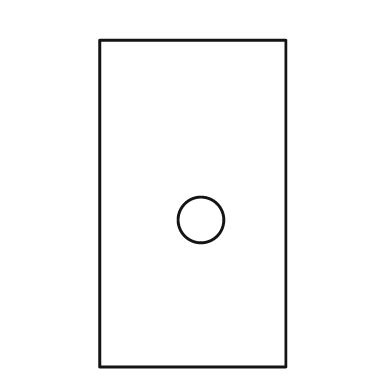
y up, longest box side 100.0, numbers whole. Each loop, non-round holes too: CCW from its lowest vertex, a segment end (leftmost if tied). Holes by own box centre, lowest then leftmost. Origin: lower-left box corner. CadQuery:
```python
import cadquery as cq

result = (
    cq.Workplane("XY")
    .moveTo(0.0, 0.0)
    .lineTo(57.0, 0.0)
    .lineTo(57.0, 100.0)
    .lineTo(0.0, 100.0)
    .close()
    .moveTo(31.0, 45.0)
    .circle(7.0)
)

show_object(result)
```